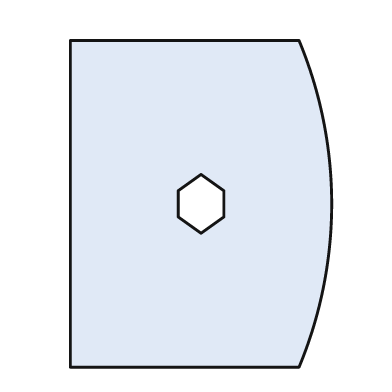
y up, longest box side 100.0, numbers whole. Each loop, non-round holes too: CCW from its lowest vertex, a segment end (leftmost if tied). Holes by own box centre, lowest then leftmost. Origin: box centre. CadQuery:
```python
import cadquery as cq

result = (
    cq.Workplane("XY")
    .moveTo(-40.0, -50.0)
    .lineTo(30.0, -50.0)
    .threePointArc((40.0, 0.0), (30.0, 50.0))
    .lineTo(-40.0, 50.0)
    .close()
    .moveTo(0.0, -9.0)
    .lineTo(7.0, -4.0)
    .lineTo(7.0, 4.0)
    .lineTo(0.0, 9.0)
    .lineTo(-7.0, 4.0)
    .lineTo(-7.0, -4.0)
    .close()
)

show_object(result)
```